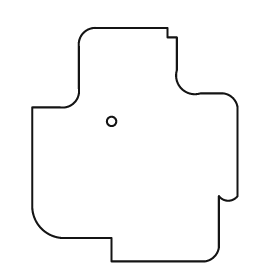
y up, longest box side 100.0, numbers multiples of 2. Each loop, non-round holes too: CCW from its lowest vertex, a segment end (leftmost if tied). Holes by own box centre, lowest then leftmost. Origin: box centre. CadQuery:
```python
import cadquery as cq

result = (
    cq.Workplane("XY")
    .moveTo(-10.0, -50.0)
    .lineTo(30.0, -50.0)
    .threePointArc((34.0, -48.0), (36.0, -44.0))
    .lineTo(36.0, -22.0)
    .threePointArc((40.0, -24.0), (44.0, -22.0))
    .lineTo(44.0, 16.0)
    .threePointArc((42.0, 20.0), (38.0, 22.0))
    .lineTo(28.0, 22.0)
    .threePointArc((20.0, 24.0), (18.0, 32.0))
    .lineTo(18.0, 46.0)
    .lineTo(14.0, 46.0)
    .lineTo(14.0, 50.0)
    .lineTo(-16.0, 50.0)
    .threePointArc((-22.0, 48.0), (-24.0, 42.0))
    .lineTo(-24.0, 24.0)
    .threePointArc((-26.0, 18.0), (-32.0, 16.0))
    .lineTo(-44.0, 16.0)
    .lineTo(-44.0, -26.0)
    .threePointArc((-40.0, -36.0), (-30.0, -40.0))
    .lineTo(-10.0, -40.0)
    .close()
    .moveTo(-10.0, 10.0)
    .circle(2.0)
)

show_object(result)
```